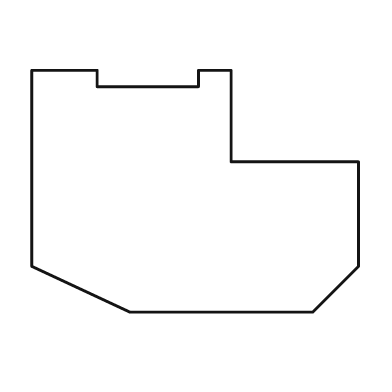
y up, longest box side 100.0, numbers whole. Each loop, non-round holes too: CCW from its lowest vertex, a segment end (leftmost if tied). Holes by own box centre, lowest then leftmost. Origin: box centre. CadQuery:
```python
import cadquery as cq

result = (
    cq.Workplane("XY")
    .moveTo(-20.0, -37.0)
    .lineTo(36.0, -37.0)
    .lineTo(50.0, -23.0)
    .lineTo(50.0, 9.0)
    .lineTo(11.0, 9.0)
    .lineTo(11.0, 37.0)
    .lineTo(1.0, 37.0)
    .lineTo(1.0, 32.0)
    .lineTo(-30.0, 32.0)
    .lineTo(-30.0, 37.0)
    .lineTo(-50.0, 37.0)
    .lineTo(-50.0, -23.0)
    .close()
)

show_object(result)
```